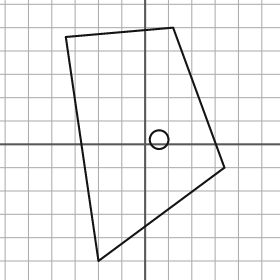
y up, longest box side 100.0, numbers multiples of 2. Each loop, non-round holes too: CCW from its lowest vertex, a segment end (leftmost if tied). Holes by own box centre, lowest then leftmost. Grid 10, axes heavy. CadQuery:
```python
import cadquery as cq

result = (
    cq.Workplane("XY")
    .moveTo(-20.0, -50.0)
    .lineTo(34.0, -10.0)
    .lineTo(12.0, 50.0)
    .lineTo(-34.0, 46.0)
    .close()
    .moveTo(6.0, 2.0)
    .circle(4.0)
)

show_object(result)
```